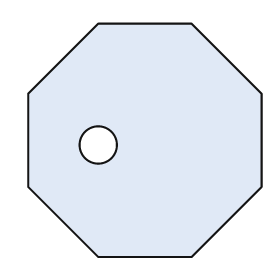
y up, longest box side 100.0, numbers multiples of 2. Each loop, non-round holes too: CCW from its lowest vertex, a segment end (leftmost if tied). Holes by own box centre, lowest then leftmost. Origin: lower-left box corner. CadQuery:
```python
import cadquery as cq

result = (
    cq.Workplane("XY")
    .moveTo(30.0, 0.0)
    .lineTo(70.0, 0.0)
    .lineTo(100.0, 30.0)
    .lineTo(100.0, 70.0)
    .lineTo(70.0, 100.0)
    .lineTo(30.0, 100.0)
    .lineTo(0.0, 70.0)
    .lineTo(0.0, 30.0)
    .close()
    .moveTo(30.0, 48.0)
    .circle(8.0)
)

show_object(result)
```